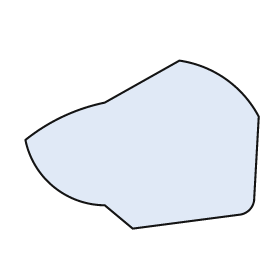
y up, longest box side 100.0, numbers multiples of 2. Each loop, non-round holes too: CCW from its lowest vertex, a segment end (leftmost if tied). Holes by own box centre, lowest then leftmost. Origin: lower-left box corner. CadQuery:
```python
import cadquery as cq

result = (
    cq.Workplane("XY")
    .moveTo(46.0, 0.0)
    .lineTo(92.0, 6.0)
    .threePointArc((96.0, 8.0), (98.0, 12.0))
    .lineTo(100.0, 48.0)
    .threePointArc((86.0, 64.0), (66.0, 72.0))
    .lineTo(34.0, 54.0)
    .threePointArc((16.0, 48.0), (0.0, 38.0))
    .threePointArc((12.0, 18.0), (34.0, 10.0))
    .close()
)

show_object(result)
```